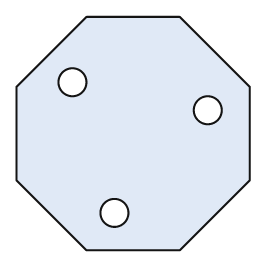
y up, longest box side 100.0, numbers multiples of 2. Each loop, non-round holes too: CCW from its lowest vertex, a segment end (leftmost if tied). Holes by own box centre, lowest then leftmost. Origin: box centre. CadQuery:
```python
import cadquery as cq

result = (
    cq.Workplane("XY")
    .moveTo(-20.0, -50.0)
    .lineTo(20.0, -50.0)
    .lineTo(50.0, -20.0)
    .lineTo(50.0, 20.0)
    .lineTo(20.0, 50.0)
    .lineTo(-20.0, 50.0)
    .lineTo(-50.0, 20.0)
    .lineTo(-50.0, -20.0)
    .close()
    .moveTo(-8.0, -34.0)
    .circle(6.0)
    .moveTo(32.0, 10.0)
    .circle(6.0)
    .moveTo(-26.0, 22.0)
    .circle(6.0)
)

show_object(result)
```